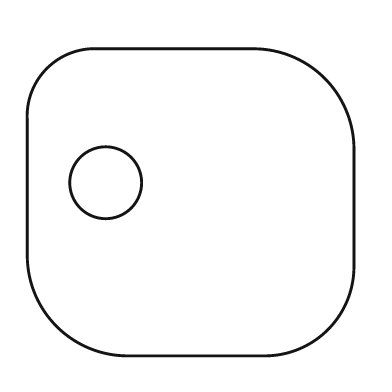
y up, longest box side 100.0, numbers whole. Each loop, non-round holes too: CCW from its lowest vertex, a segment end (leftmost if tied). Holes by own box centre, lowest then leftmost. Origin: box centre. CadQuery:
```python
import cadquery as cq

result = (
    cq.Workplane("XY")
    .moveTo(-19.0, -47.0)
    .lineTo(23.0, -47.0)
    .threePointArc((42.0, -39.0), (50.0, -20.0))
    .lineTo(50.0, 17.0)
    .threePointArc((41.0, 38.0), (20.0, 47.0))
    .lineTo(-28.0, 47.0)
    .threePointArc((-44.0, 41.0), (-50.0, 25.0))
    .lineTo(-50.0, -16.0)
    .threePointArc((-41.0, -38.0), (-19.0, -47.0))
    .close()
    .moveTo(-26.0, 6.0)
    .circle(11.0)
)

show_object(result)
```